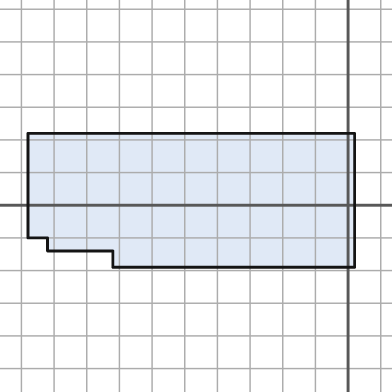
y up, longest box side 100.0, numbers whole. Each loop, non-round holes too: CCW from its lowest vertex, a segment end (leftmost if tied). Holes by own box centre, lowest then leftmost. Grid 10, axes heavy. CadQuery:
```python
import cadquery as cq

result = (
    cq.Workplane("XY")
    .moveTo(-72.0, -19.0)
    .lineTo(2.0, -19.0)
    .lineTo(2.0, 22.0)
    .lineTo(-98.0, 22.0)
    .lineTo(-98.0, -10.0)
    .lineTo(-92.0, -10.0)
    .lineTo(-92.0, -14.0)
    .lineTo(-72.0, -14.0)
    .close()
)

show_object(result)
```